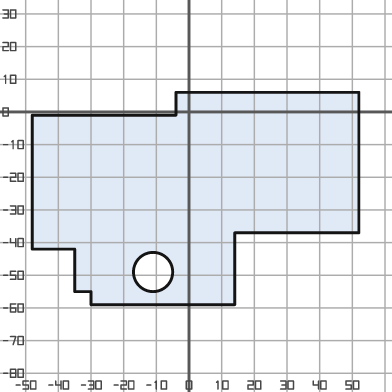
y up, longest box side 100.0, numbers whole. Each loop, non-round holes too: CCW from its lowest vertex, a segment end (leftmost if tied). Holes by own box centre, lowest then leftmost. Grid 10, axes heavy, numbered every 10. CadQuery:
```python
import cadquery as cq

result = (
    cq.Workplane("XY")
    .moveTo(-30.0, -59.0)
    .lineTo(14.0, -59.0)
    .lineTo(14.0, -37.0)
    .lineTo(52.0, -37.0)
    .lineTo(52.0, 6.0)
    .lineTo(-4.0, 6.0)
    .lineTo(-4.0, -1.0)
    .lineTo(-48.0, -1.0)
    .lineTo(-48.0, -42.0)
    .lineTo(-35.0, -42.0)
    .lineTo(-35.0, -55.0)
    .lineTo(-30.0, -55.0)
    .close()
    .moveTo(-11.0, -49.0)
    .circle(6.0)
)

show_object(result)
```